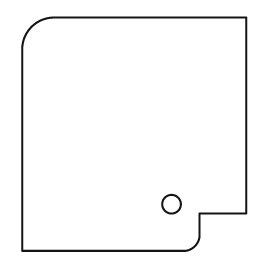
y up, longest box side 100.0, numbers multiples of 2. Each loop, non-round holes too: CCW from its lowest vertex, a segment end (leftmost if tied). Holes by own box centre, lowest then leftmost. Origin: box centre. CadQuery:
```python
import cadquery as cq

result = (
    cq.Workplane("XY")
    .moveTo(-48.0, -50.0)
    .lineTo(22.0, -50.0)
    .threePointArc((26.0, -48.0), (28.0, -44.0))
    .lineTo(28.0, -34.0)
    .lineTo(48.0, -34.0)
    .lineTo(48.0, 50.0)
    .lineTo(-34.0, 50.0)
    .threePointArc((-44.0, 46.0), (-48.0, 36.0))
    .close()
    .moveTo(16.0, -30.0)
    .circle(4.0)
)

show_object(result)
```